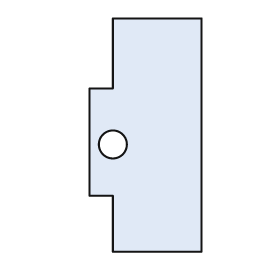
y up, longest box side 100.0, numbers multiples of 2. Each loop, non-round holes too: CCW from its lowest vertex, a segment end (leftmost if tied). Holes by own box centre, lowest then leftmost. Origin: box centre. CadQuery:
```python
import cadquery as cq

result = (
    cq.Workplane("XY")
    .moveTo(-14.0, -50.0)
    .lineTo(24.0, -50.0)
    .lineTo(24.0, 50.0)
    .lineTo(-14.0, 50.0)
    .lineTo(-14.0, 20.0)
    .lineTo(-24.0, 20.0)
    .lineTo(-24.0, -26.0)
    .lineTo(-14.0, -26.0)
    .close()
    .moveTo(-14.0, -4.0)
    .circle(6.0)
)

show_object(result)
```